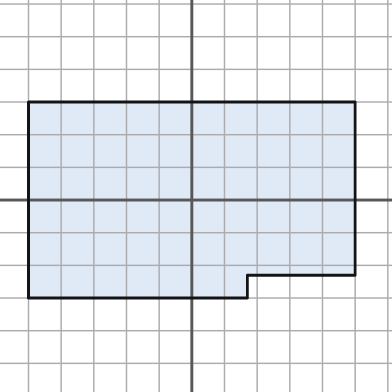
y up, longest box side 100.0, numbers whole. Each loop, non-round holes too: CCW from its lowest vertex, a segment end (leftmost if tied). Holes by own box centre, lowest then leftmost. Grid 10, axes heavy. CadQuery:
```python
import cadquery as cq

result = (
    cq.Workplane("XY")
    .moveTo(-50.0, -30.0)
    .lineTo(17.0, -30.0)
    .lineTo(17.0, -23.0)
    .lineTo(50.0, -23.0)
    .lineTo(50.0, 30.0)
    .lineTo(-50.0, 30.0)
    .close()
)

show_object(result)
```